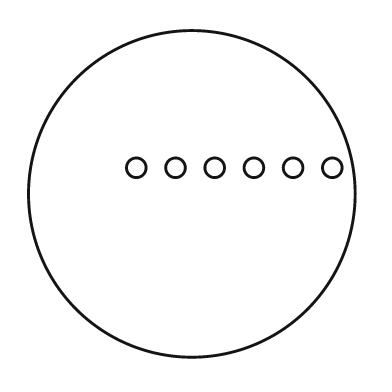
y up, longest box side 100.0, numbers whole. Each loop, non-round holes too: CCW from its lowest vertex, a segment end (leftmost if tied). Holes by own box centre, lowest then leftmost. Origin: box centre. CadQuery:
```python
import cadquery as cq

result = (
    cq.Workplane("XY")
    .moveTo(0.0, 0.0)
    .circle(50.0)
    .moveTo(-17.0, 8.0)
    .circle(3.0)
    .moveTo(-5.0, 8.0)
    .circle(3.0)
    .moveTo(7.0, 8.0)
    .circle(3.0)
    .moveTo(19.0, 8.0)
    .circle(3.0)
    .moveTo(31.0, 8.0)
    .circle(3.0)
    .moveTo(43.0, 8.0)
    .circle(3.0)
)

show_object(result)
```